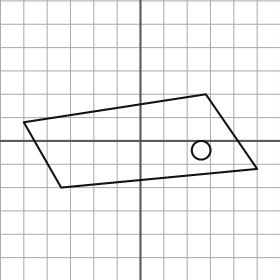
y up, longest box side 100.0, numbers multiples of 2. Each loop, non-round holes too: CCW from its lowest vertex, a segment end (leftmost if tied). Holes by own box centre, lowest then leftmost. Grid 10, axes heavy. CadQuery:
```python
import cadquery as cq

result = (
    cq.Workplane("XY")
    .moveTo(-34.0, -20.0)
    .lineTo(50.0, -12.0)
    .lineTo(28.0, 20.0)
    .lineTo(-50.0, 8.0)
    .close()
    .moveTo(26.0, -4.0)
    .circle(4.0)
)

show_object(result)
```